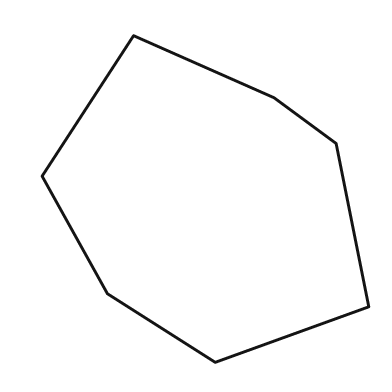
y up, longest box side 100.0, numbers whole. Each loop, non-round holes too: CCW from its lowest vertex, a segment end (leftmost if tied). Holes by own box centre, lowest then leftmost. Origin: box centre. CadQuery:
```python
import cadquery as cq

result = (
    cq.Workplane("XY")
    .moveTo(3.0, -50.0)
    .lineTo(50.0, -33.0)
    .lineTo(40.0, 17.0)
    .lineTo(21.0, 31.0)
    .lineTo(-22.0, 50.0)
    .lineTo(-50.0, 7.0)
    .lineTo(-30.0, -29.0)
    .close()
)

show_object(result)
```